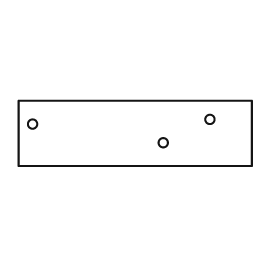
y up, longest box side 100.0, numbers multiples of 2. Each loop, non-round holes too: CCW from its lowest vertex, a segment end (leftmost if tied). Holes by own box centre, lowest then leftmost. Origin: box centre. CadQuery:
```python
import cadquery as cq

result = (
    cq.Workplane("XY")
    .moveTo(-50.0, -14.0)
    .lineTo(50.0, -14.0)
    .lineTo(50.0, 14.0)
    .lineTo(-50.0, 14.0)
    .close()
    .moveTo(12.0, -4.0)
    .circle(2.0)
    .moveTo(-44.0, 4.0)
    .circle(2.0)
    .moveTo(32.0, 6.0)
    .circle(2.0)
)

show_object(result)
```